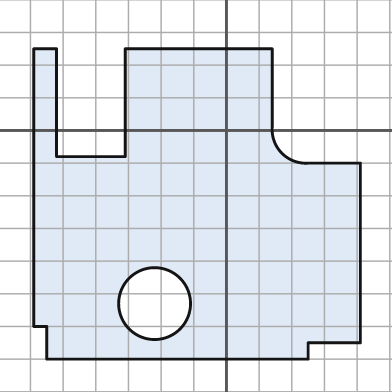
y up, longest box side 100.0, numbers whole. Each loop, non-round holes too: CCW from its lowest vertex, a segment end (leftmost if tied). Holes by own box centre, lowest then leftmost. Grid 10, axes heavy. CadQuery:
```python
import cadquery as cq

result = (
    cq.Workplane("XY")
    .moveTo(-55.0, -70.0)
    .lineTo(25.0, -70.0)
    .lineTo(25.0, -65.0)
    .lineTo(41.0, -65.0)
    .lineTo(41.0, -10.0)
    .lineTo(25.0, -10.0)
    .threePointArc((17.0, -7.0), (14.0, 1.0))
    .lineTo(14.0, 25.0)
    .lineTo(-31.0, 25.0)
    .lineTo(-31.0, -8.0)
    .lineTo(-52.0, -8.0)
    .lineTo(-52.0, 25.0)
    .lineTo(-59.0, 25.0)
    .lineTo(-59.0, -60.0)
    .lineTo(-55.0, -60.0)
    .close()
    .moveTo(-22.0, -53.0)
    .circle(11.0)
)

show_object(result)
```